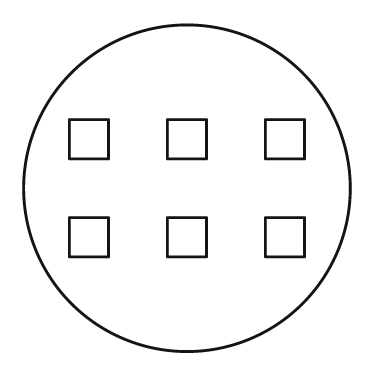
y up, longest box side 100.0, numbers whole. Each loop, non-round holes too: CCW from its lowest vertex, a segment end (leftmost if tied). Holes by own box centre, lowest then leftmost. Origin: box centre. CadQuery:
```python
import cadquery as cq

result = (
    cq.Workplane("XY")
    .moveTo(0.0, 0.0)
    .circle(50.0)
    .moveTo(-36.0, -21.0)
    .lineTo(-24.0, -21.0)
    .lineTo(-24.0, -9.0)
    .lineTo(-36.0, -9.0)
    .close()
    .moveTo(-6.0, -21.0)
    .lineTo(6.0, -21.0)
    .lineTo(6.0, -9.0)
    .lineTo(-6.0, -9.0)
    .close()
    .moveTo(24.0, -21.0)
    .lineTo(36.0, -21.0)
    .lineTo(36.0, -9.0)
    .lineTo(24.0, -9.0)
    .close()
    .moveTo(-36.0, 9.0)
    .lineTo(-24.0, 9.0)
    .lineTo(-24.0, 21.0)
    .lineTo(-36.0, 21.0)
    .close()
    .moveTo(-6.0, 9.0)
    .lineTo(6.0, 9.0)
    .lineTo(6.0, 21.0)
    .lineTo(-6.0, 21.0)
    .close()
    .moveTo(24.0, 9.0)
    .lineTo(36.0, 9.0)
    .lineTo(36.0, 21.0)
    .lineTo(24.0, 21.0)
    .close()
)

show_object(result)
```